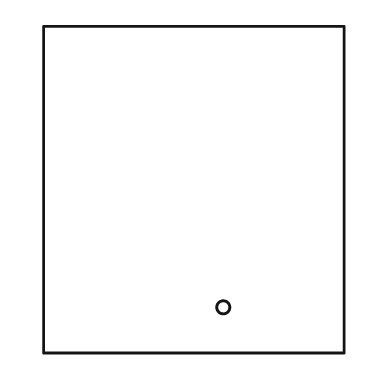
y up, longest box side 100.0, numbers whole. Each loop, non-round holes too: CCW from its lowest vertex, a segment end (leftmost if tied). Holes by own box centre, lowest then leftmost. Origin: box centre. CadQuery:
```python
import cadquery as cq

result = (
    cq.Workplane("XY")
    .moveTo(-46.0, -50.0)
    .lineTo(46.0, -50.0)
    .lineTo(46.0, 50.0)
    .lineTo(-46.0, 50.0)
    .close()
    .moveTo(9.0, -36.0)
    .circle(2.0)
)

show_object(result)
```